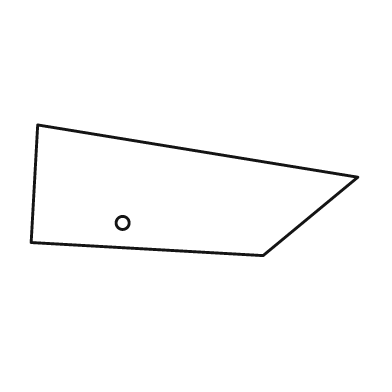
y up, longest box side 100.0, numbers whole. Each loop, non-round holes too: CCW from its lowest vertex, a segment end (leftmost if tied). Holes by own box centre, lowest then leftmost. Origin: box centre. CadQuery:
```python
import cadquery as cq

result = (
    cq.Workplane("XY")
    .moveTo(21.0, -20.0)
    .lineTo(50.0, 4.0)
    .lineTo(-48.0, 20.0)
    .lineTo(-50.0, -16.0)
    .close()
    .moveTo(-22.0, -10.0)
    .circle(2.0)
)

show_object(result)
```